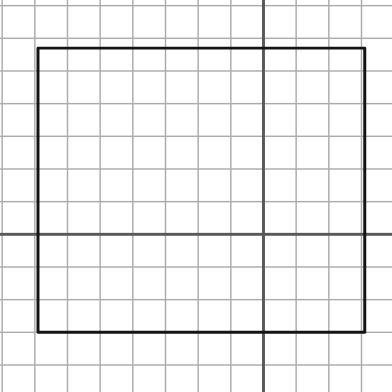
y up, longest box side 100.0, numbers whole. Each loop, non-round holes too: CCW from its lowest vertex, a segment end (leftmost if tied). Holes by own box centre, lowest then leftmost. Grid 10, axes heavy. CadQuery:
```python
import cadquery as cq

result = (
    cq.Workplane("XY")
    .moveTo(-69.0, -30.0)
    .lineTo(31.0, -30.0)
    .lineTo(31.0, 57.0)
    .lineTo(-69.0, 57.0)
    .close()
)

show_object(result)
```